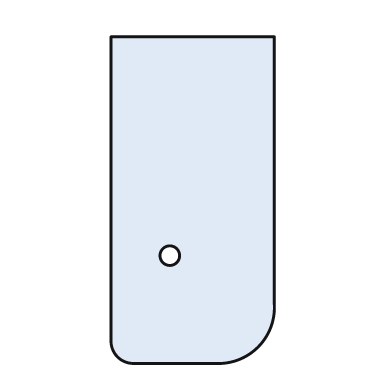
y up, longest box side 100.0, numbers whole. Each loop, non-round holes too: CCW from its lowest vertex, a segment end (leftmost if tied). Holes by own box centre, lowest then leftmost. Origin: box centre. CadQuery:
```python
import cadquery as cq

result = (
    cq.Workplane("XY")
    .moveTo(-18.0, -50.0)
    .lineTo(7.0, -50.0)
    .threePointArc((20.0, -45.0), (25.0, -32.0))
    .lineTo(25.0, 50.0)
    .lineTo(-25.0, 50.0)
    .lineTo(-25.0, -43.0)
    .threePointArc((-23.0, -48.0), (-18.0, -50.0))
    .close()
    .moveTo(-7.0, -17.0)
    .circle(3.0)
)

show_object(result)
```